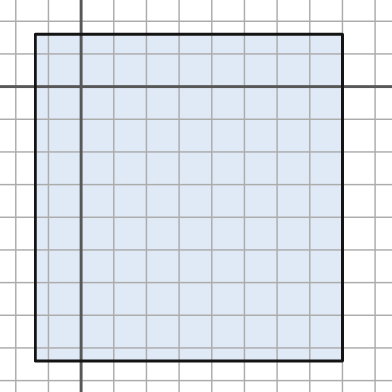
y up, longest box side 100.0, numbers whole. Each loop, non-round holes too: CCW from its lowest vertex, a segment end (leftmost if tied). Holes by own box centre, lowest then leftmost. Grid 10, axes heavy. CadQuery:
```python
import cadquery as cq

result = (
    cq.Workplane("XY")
    .moveTo(-14.0, -84.0)
    .lineTo(80.0, -84.0)
    .lineTo(80.0, 16.0)
    .lineTo(-14.0, 16.0)
    .close()
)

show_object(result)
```